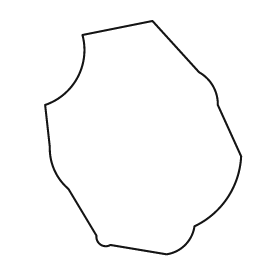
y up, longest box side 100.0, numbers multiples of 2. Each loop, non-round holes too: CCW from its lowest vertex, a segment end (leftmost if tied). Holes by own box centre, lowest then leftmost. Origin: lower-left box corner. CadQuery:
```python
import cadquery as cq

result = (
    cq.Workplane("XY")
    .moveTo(52.0, 0.0)
    .threePointArc((60.0, 4.0), (64.0, 12.0))
    .threePointArc((78.0, 24.0), (84.0, 42.0))
    .lineTo(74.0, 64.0)
    .threePointArc((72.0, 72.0), (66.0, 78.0))
    .lineTo(46.0, 100.0)
    .lineTo(16.0, 94.0)
    .threePointArc((14.0, 76.0), (0.0, 64.0))
    .lineTo(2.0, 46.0)
    .threePointArc((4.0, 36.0), (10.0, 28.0))
    .lineTo(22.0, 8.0)
    .threePointArc((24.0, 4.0), (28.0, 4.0))
    .close()
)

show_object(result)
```